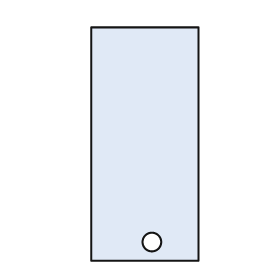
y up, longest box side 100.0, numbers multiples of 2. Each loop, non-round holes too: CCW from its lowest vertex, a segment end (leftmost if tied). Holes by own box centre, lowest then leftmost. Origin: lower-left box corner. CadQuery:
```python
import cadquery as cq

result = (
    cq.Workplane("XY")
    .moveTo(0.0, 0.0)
    .lineTo(46.0, 0.0)
    .lineTo(46.0, 100.0)
    .lineTo(0.0, 100.0)
    .close()
    .moveTo(26.0, 8.0)
    .circle(4.0)
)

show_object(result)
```